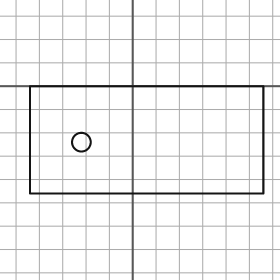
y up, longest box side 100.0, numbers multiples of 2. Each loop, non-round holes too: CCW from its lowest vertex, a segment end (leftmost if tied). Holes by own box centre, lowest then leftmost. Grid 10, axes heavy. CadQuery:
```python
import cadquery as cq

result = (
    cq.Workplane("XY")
    .moveTo(-44.0, -46.0)
    .lineTo(56.0, -46.0)
    .lineTo(56.0, 0.0)
    .lineTo(-44.0, 0.0)
    .close()
    .moveTo(-22.0, -24.0)
    .circle(4.0)
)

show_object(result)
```